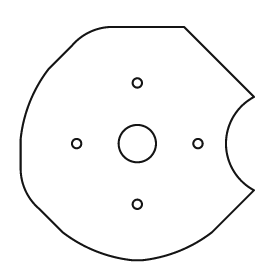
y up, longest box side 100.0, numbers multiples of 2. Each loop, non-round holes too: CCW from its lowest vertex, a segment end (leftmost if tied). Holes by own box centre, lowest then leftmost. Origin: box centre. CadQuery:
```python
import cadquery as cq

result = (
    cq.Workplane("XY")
    .moveTo(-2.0, -50.0)
    .lineTo(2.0, -50.0)
    .threePointArc((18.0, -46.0), (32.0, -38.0))
    .lineTo(50.0, -20.0)
    .threePointArc((38.0, 0.0), (50.0, 20.0))
    .lineTo(20.0, 50.0)
    .lineTo(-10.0, 50.0)
    .threePointArc((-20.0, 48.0), (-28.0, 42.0))
    .lineTo(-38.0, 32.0)
    .threePointArc((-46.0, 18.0), (-50.0, 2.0))
    .lineTo(-50.0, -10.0)
    .threePointArc((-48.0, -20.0), (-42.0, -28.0))
    .lineTo(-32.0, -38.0)
    .threePointArc((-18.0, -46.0), (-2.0, -50.0))
    .close()
    .moveTo(0.0, -26.0)
    .circle(2.0)
    .moveTo(-26.0, 0.0)
    .circle(2.0)
    .moveTo(0.0, 0.0)
    .circle(8.0)
    .moveTo(26.0, 0.0)
    .circle(2.0)
    .moveTo(0.0, 26.0)
    .circle(2.0)
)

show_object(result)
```